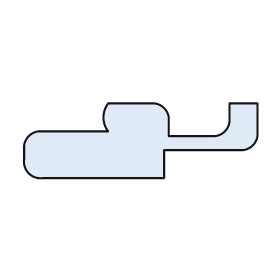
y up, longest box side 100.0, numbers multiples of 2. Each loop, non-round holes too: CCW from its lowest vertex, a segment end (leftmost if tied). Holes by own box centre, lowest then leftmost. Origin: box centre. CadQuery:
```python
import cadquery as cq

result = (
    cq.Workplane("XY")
    .moveTo(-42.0, -16.0)
    .lineTo(10.0, -16.0)
    .lineTo(10.0, -4.0)
    .lineTo(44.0, -4.0)
    .threePointArc((48.0, -2.0), (50.0, 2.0))
    .lineTo(50.0, 16.0)
    .lineTo(38.0, 16.0)
    .lineTo(38.0, 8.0)
    .threePointArc((36.0, 4.0), (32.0, 2.0))
    .lineTo(12.0, 2.0)
    .lineTo(12.0, 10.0)
    .threePointArc((10.0, 14.0), (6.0, 16.0))
    .lineTo(-14.0, 16.0)
    .threePointArc((-16.0, 10.0), (-14.0, 4.0))
    .lineTo(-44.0, 4.0)
    .threePointArc((-48.0, 2.0), (-50.0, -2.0))
    .lineTo(-50.0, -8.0)
    .threePointArc((-48.0, -14.0), (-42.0, -16.0))
    .close()
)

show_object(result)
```